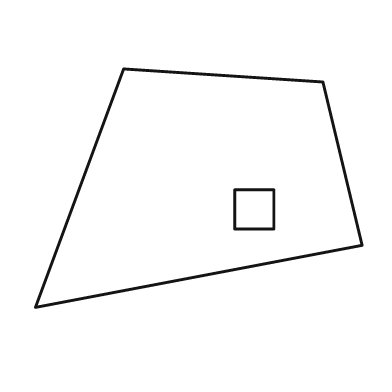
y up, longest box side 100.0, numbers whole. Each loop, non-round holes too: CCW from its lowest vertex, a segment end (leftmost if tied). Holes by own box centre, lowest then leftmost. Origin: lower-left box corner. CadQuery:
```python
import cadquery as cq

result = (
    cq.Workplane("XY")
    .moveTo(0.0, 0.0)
    .lineTo(100.0, 19.0)
    .lineTo(88.0, 69.0)
    .lineTo(27.0, 73.0)
    .close()
    .moveTo(61.0, 24.0)
    .lineTo(73.0, 24.0)
    .lineTo(73.0, 36.0)
    .lineTo(61.0, 36.0)
    .close()
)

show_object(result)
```